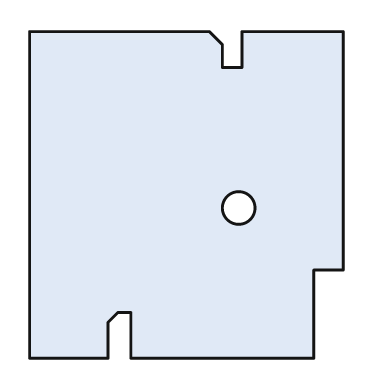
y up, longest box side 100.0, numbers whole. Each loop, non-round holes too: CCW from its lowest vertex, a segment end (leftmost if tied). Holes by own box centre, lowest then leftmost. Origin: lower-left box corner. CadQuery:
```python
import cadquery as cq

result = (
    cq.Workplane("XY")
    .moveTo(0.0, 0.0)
    .lineTo(24.0, 0.0)
    .lineTo(24.0, 11.0)
    .lineTo(27.0, 14.0)
    .lineTo(31.0, 14.0)
    .lineTo(31.0, 0.0)
    .lineTo(87.0, 0.0)
    .lineTo(87.0, 27.0)
    .lineTo(96.0, 27.0)
    .lineTo(96.0, 100.0)
    .lineTo(65.0, 100.0)
    .lineTo(65.0, 89.0)
    .lineTo(59.0, 89.0)
    .lineTo(59.0, 96.0)
    .lineTo(55.0, 100.0)
    .lineTo(0.0, 100.0)
    .close()
    .moveTo(64.0, 46.0)
    .circle(5.0)
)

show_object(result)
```